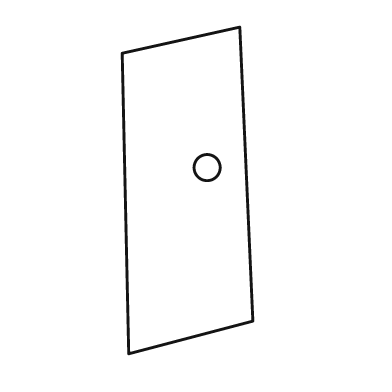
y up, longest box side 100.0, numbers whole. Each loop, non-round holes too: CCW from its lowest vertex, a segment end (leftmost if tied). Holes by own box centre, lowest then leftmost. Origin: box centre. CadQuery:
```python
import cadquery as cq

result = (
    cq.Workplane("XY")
    .moveTo(-18.0, -50.0)
    .lineTo(20.0, -40.0)
    .lineTo(16.0, 50.0)
    .lineTo(-20.0, 42.0)
    .close()
    .moveTo(6.0, 7.0)
    .circle(4.0)
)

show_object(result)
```